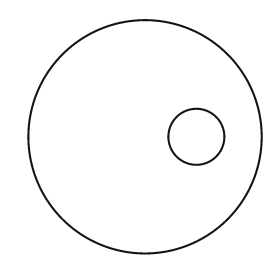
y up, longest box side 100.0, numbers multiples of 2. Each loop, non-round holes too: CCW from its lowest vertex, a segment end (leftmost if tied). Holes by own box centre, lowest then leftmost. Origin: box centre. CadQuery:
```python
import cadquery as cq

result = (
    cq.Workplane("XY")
    .moveTo(0.0, 0.0)
    .circle(50.0)
    .moveTo(22.0, 0.0)
    .circle(12.0)
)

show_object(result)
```